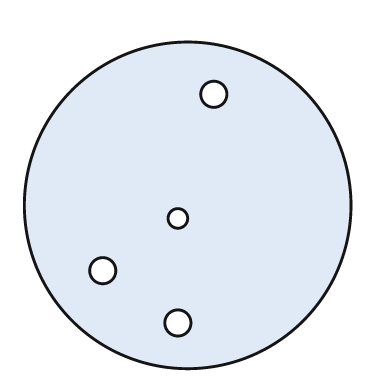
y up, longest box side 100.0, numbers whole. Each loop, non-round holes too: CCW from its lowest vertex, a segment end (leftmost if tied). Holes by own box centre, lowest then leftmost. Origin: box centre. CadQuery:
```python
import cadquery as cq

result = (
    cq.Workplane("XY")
    .moveTo(0.0, 0.0)
    .circle(50.0)
    .moveTo(-3.0, -36.0)
    .circle(4.0)
    .moveTo(-26.0, -20.0)
    .circle(4.0)
    .moveTo(-3.0, -4.0)
    .circle(3.0)
    .moveTo(8.0, 34.0)
    .circle(4.0)
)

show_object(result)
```